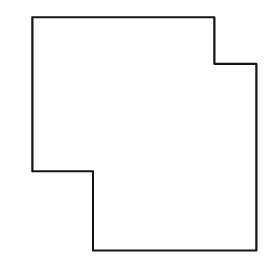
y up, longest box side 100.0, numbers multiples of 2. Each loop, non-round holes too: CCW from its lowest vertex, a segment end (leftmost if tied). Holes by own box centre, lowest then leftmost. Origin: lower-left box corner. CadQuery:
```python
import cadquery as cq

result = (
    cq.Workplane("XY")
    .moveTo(26.0, 0.0)
    .lineTo(96.0, 0.0)
    .lineTo(96.0, 80.0)
    .lineTo(78.0, 80.0)
    .lineTo(78.0, 100.0)
    .lineTo(0.0, 100.0)
    .lineTo(0.0, 34.0)
    .lineTo(26.0, 34.0)
    .close()
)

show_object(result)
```